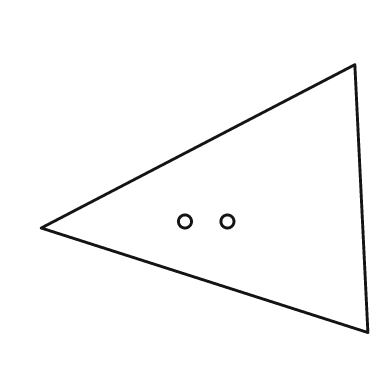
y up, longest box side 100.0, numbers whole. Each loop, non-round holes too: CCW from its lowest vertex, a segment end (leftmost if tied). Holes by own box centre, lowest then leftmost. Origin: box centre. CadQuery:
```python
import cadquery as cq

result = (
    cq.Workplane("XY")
    .moveTo(50.0, -41.0)
    .lineTo(46.0, 41.0)
    .lineTo(-50.0, -9.0)
    .close()
    .moveTo(-6.0, -7.0)
    .circle(2.0)
    .moveTo(7.0, -7.0)
    .circle(2.0)
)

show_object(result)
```